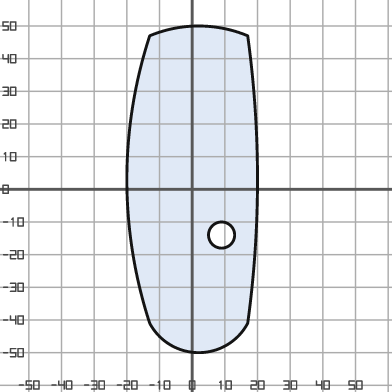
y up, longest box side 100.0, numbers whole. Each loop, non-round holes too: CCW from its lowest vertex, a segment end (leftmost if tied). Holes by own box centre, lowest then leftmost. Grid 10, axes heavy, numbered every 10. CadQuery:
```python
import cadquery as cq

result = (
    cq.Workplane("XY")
    .moveTo(-13.0, -41.0)
    .threePointArc((2.0, -50.0), (17.0, -41.0))
    .threePointArc((20.0, 3.0), (17.0, 47.0))
    .threePointArc((2.0, 50.0), (-13.0, 47.0))
    .threePointArc((-20.0, 3.0), (-13.0, -41.0))
    .close()
    .moveTo(9.0, -14.0)
    .circle(4.0)
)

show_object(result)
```